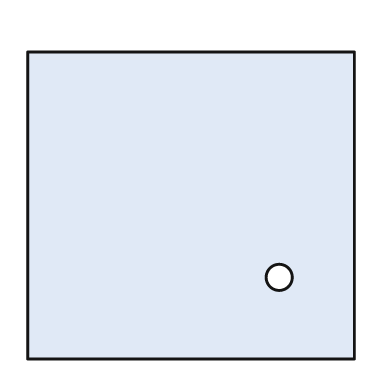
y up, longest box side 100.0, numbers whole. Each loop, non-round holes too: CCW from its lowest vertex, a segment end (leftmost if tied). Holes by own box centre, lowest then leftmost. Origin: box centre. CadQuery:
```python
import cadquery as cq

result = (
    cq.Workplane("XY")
    .moveTo(-50.0, -47.0)
    .lineTo(50.0, -47.0)
    .lineTo(50.0, 47.0)
    .lineTo(-50.0, 47.0)
    .close()
    .moveTo(27.0, -22.0)
    .circle(4.0)
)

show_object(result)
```